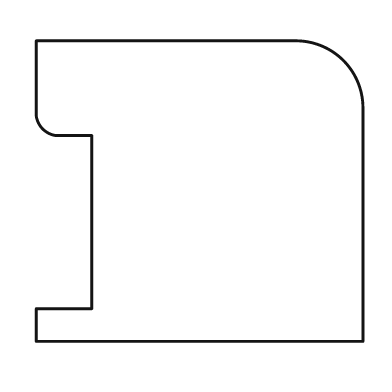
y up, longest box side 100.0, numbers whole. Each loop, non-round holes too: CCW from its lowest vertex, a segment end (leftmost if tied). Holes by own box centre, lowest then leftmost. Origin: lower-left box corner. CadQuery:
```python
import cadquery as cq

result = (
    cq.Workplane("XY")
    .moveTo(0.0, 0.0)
    .lineTo(100.0, 0.0)
    .lineTo(100.0, 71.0)
    .threePointArc((94.0, 86.0), (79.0, 92.0))
    .lineTo(0.0, 92.0)
    .lineTo(0.0, 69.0)
    .threePointArc((2.0, 65.0), (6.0, 63.0))
    .lineTo(17.0, 63.0)
    .lineTo(17.0, 10.0)
    .lineTo(0.0, 10.0)
    .close()
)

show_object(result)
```